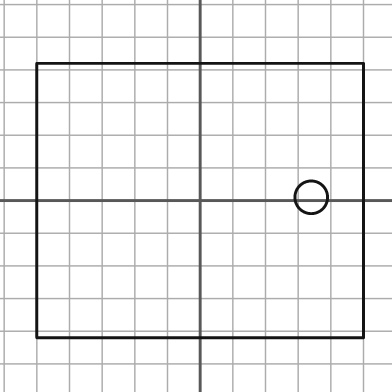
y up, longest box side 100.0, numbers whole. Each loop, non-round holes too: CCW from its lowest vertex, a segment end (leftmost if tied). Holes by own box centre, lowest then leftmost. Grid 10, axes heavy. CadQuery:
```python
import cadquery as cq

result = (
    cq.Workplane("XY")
    .moveTo(-50.0, -42.0)
    .lineTo(50.0, -42.0)
    .lineTo(50.0, 42.0)
    .lineTo(-50.0, 42.0)
    .close()
    .moveTo(34.0, 1.0)
    .circle(5.0)
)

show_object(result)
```